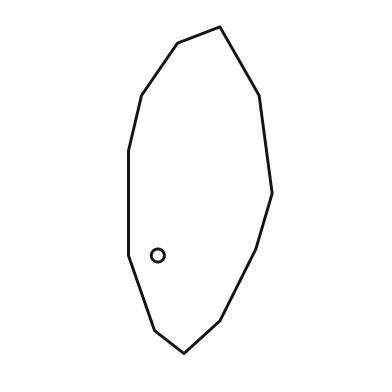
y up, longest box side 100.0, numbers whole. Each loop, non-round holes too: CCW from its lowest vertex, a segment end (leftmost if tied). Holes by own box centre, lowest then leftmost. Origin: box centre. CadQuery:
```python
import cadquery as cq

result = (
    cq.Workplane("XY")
    .moveTo(-5.0, -50.0)
    .lineTo(6.0, -40.0)
    .lineTo(17.0, -18.0)
    .lineTo(22.0, -1.0)
    .lineTo(18.0, 29.0)
    .lineTo(6.0, 50.0)
    .lineTo(-7.0, 45.0)
    .lineTo(-18.0, 29.0)
    .lineTo(-22.0, 12.0)
    .lineTo(-22.0, -20.0)
    .lineTo(-14.0, -43.0)
    .close()
    .moveTo(-13.0, -20.0)
    .circle(2.0)
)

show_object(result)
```